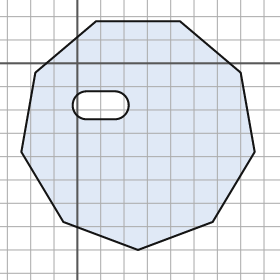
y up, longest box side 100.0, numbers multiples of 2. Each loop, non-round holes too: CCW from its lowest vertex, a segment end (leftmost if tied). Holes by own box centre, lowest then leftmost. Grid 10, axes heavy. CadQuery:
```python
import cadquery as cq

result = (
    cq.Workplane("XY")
    .moveTo(26.0, -80.0)
    .lineTo(58.0, -68.0)
    .lineTo(76.0, -38.0)
    .lineTo(70.0, -4.0)
    .lineTo(44.0, 18.0)
    .lineTo(8.0, 18.0)
    .lineTo(-18.0, -4.0)
    .lineTo(-24.0, -38.0)
    .lineTo(-6.0, -68.0)
    .close()
    .moveTo(4.0, -24.0)
    .lineTo(16.0, -24.0)
    .threePointArc((22.0, -18.0), (16.0, -12.0))
    .lineTo(4.0, -12.0)
    .threePointArc((-2.0, -18.0), (4.0, -24.0))
    .close()
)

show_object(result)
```